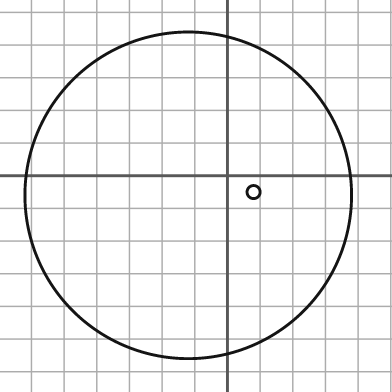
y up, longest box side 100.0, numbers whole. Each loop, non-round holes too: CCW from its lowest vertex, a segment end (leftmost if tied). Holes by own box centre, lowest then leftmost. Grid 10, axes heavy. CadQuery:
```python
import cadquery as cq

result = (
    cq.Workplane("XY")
    .moveTo(-12.0, -6.0)
    .circle(50.0)
    .moveTo(8.0, -5.0)
    .circle(2.0)
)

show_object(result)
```